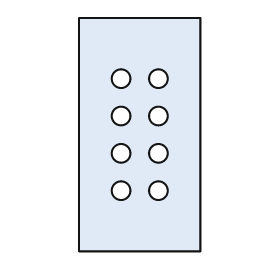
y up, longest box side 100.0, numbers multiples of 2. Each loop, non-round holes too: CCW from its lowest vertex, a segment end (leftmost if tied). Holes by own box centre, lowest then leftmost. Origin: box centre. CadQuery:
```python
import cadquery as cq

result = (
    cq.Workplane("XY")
    .moveTo(-26.0, -50.0)
    .lineTo(26.0, -50.0)
    .lineTo(26.0, 50.0)
    .lineTo(-26.0, 50.0)
    .close()
    .moveTo(-8.0, -24.0)
    .circle(4.0)
    .moveTo(8.0, -24.0)
    .circle(4.0)
    .moveTo(-8.0, -8.0)
    .circle(4.0)
    .moveTo(8.0, -8.0)
    .circle(4.0)
    .moveTo(-8.0, 8.0)
    .circle(4.0)
    .moveTo(8.0, 8.0)
    .circle(4.0)
    .moveTo(-8.0, 24.0)
    .circle(4.0)
    .moveTo(8.0, 24.0)
    .circle(4.0)
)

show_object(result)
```